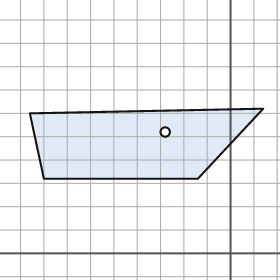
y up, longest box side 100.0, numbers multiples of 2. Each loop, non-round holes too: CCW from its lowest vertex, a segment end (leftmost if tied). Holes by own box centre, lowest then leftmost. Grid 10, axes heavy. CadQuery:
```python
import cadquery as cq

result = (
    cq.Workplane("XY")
    .moveTo(-80.0, 32.0)
    .lineTo(-14.0, 32.0)
    .lineTo(14.0, 62.0)
    .lineTo(-86.0, 60.0)
    .close()
    .moveTo(-28.0, 52.0)
    .circle(2.0)
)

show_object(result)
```